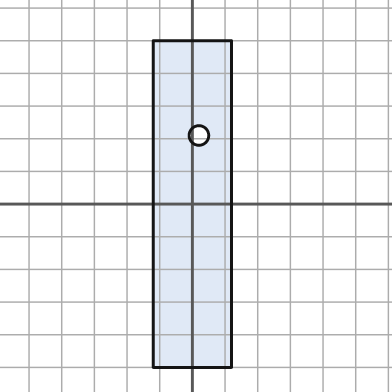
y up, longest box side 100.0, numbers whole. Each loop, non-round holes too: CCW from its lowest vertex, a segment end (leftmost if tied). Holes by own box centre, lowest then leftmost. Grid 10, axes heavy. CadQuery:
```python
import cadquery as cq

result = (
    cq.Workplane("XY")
    .moveTo(-12.0, -50.0)
    .lineTo(12.0, -50.0)
    .lineTo(12.0, 50.0)
    .lineTo(-12.0, 50.0)
    .close()
    .moveTo(2.0, 21.0)
    .circle(3.0)
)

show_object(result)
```